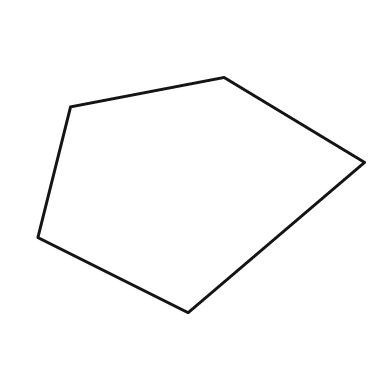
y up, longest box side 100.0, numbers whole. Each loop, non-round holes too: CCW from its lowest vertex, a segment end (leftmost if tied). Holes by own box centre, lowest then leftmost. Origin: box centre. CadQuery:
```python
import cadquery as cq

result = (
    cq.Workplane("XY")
    .moveTo(-4.0, -36.0)
    .lineTo(50.0, 10.0)
    .lineTo(7.0, 36.0)
    .lineTo(-40.0, 27.0)
    .lineTo(-50.0, -13.0)
    .close()
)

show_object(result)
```